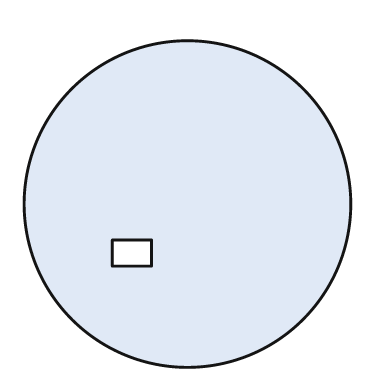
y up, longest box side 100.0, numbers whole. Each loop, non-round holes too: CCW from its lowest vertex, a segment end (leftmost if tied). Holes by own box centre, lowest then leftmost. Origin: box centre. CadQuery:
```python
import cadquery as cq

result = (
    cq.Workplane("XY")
    .moveTo(0.0, 0.0)
    .circle(50.0)
    .moveTo(-23.0, -19.0)
    .lineTo(-11.0, -19.0)
    .lineTo(-11.0, -11.0)
    .lineTo(-23.0, -11.0)
    .close()
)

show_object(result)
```